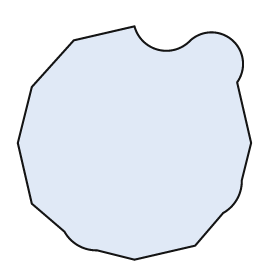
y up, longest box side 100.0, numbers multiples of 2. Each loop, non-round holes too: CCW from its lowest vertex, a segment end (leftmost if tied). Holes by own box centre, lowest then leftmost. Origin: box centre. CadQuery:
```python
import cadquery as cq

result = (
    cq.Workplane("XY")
    .moveTo(0.0, -50.0)
    .lineTo(26.0, -44.0)
    .lineTo(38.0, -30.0)
    .threePointArc((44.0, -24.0), (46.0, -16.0))
    .lineTo(50.0, 0.0)
    .lineTo(44.0, 26.0)
    .threePointArc((42.0, 44.0), (24.0, 44.0))
    .threePointArc((10.0, 40.0), (0.0, 50.0))
    .lineTo(-26.0, 44.0)
    .lineTo(-44.0, 24.0)
    .lineTo(-50.0, 0.0)
    .lineTo(-44.0, -26.0)
    .lineTo(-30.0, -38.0)
    .threePointArc((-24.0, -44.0), (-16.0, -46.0))
    .close()
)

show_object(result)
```